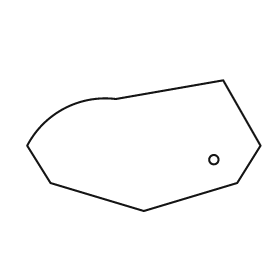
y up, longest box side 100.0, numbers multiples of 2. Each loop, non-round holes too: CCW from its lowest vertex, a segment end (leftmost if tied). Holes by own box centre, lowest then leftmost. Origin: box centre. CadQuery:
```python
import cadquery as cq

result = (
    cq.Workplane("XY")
    .moveTo(0.0, -28.0)
    .lineTo(40.0, -16.0)
    .lineTo(50.0, 0.0)
    .lineTo(34.0, 28.0)
    .lineTo(-12.0, 20.0)
    .threePointArc((-34.0, 16.0), (-50.0, 0.0))
    .lineTo(-40.0, -16.0)
    .close()
    .moveTo(30.0, -6.0)
    .circle(2.0)
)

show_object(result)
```